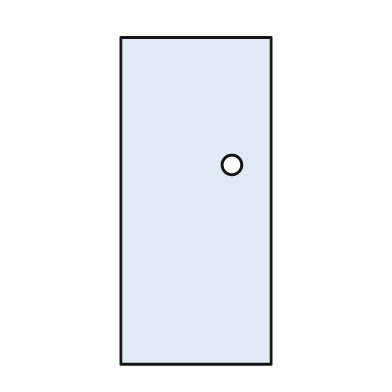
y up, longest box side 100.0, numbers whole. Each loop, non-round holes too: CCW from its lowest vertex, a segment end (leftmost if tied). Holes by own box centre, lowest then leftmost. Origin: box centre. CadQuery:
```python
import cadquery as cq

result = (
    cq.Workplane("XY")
    .moveTo(-23.0, -50.0)
    .lineTo(23.0, -50.0)
    .lineTo(23.0, 50.0)
    .lineTo(-23.0, 50.0)
    .close()
    .moveTo(11.0, 11.0)
    .circle(3.0)
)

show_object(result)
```